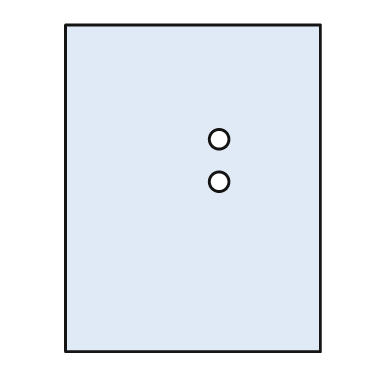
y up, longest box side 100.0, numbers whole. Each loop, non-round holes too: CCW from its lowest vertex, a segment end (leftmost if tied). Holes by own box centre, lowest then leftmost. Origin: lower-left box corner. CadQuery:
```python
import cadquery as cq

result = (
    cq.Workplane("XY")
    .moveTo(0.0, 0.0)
    .lineTo(78.0, 0.0)
    .lineTo(78.0, 100.0)
    .lineTo(0.0, 100.0)
    .close()
    .moveTo(47.0, 52.0)
    .circle(3.0)
    .moveTo(47.0, 65.0)
    .circle(3.0)
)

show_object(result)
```